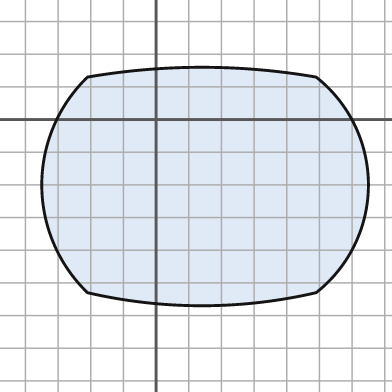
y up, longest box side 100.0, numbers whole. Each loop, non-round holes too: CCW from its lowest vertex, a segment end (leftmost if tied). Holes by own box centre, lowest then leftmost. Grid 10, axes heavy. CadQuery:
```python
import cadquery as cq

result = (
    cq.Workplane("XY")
    .moveTo(-21.0, -53.0)
    .threePointArc((14.0, -57.0), (49.0, -53.0))
    .threePointArc((65.0, -20.0), (49.0, 13.0))
    .threePointArc((14.0, 16.0), (-21.0, 13.0))
    .threePointArc((-35.0, -20.0), (-21.0, -53.0))
    .close()
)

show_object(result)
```